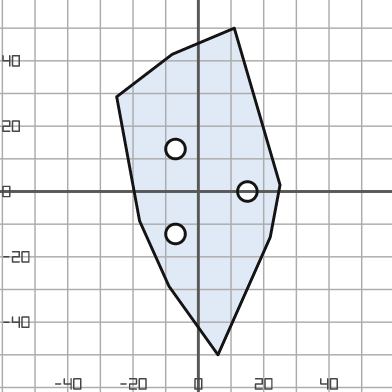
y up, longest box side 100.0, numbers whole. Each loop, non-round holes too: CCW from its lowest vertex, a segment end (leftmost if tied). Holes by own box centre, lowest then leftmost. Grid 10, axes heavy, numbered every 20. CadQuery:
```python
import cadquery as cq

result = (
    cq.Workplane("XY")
    .moveTo(6.0, -50.0)
    .lineTo(22.0, -14.0)
    .lineTo(25.0, 2.0)
    .lineTo(11.0, 50.0)
    .lineTo(-8.0, 42.0)
    .lineTo(-25.0, 29.0)
    .lineTo(-18.0, -9.0)
    .lineTo(-9.0, -29.0)
    .close()
    .moveTo(-7.0, -13.0)
    .circle(3.0)
    .moveTo(15.0, 0.0)
    .circle(3.0)
    .moveTo(-7.0, 13.0)
    .circle(3.0)
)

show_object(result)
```